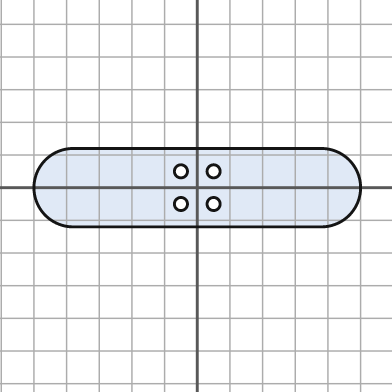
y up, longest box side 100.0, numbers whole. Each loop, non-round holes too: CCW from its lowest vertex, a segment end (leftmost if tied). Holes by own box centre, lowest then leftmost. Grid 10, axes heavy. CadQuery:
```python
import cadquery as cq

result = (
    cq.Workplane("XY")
    .moveTo(-38.0, -12.0)
    .lineTo(38.0, -12.0)
    .threePointArc((50.0, 0.0), (38.0, 12.0))
    .lineTo(-38.0, 12.0)
    .threePointArc((-50.0, 0.0), (-38.0, -12.0))
    .close()
    .moveTo(-5.0, -5.0)
    .circle(2.0)
    .moveTo(5.0, -5.0)
    .circle(2.0)
    .moveTo(-5.0, 5.0)
    .circle(2.0)
    .moveTo(5.0, 5.0)
    .circle(2.0)
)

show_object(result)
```